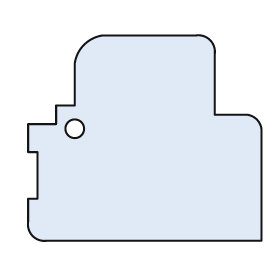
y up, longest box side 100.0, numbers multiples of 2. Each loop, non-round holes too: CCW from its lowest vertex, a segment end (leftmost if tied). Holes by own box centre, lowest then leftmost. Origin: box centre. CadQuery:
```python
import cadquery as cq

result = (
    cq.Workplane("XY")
    .moveTo(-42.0, -44.0)
    .lineTo(50.0, -44.0)
    .lineTo(50.0, 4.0)
    .threePointArc((48.0, 8.0), (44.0, 10.0))
    .lineTo(30.0, 10.0)
    .lineTo(30.0, 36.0)
    .threePointArc((28.0, 42.0), (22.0, 44.0))
    .lineTo(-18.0, 44.0)
    .threePointArc((-26.0, 40.0), (-30.0, 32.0))
    .lineTo(-30.0, 14.0)
    .lineTo(-38.0, 14.0)
    .lineTo(-38.0, 6.0)
    .lineTo(-50.0, 6.0)
    .lineTo(-50.0, -6.0)
    .lineTo(-46.0, -6.0)
    .lineTo(-46.0, -26.0)
    .lineTo(-50.0, -26.0)
    .lineTo(-50.0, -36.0)
    .threePointArc((-48.0, -42.0), (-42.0, -44.0))
    .close()
    .moveTo(-30.0, 4.0)
    .circle(4.0)
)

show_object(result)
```